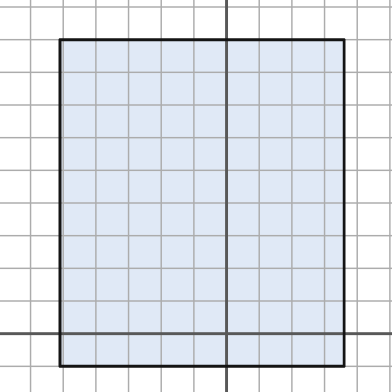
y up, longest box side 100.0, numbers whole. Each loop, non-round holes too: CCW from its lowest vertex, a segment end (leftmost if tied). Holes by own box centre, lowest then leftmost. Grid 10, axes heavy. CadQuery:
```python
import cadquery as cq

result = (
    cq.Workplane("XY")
    .moveTo(-51.0, -10.0)
    .lineTo(36.0, -10.0)
    .lineTo(36.0, 90.0)
    .lineTo(-51.0, 90.0)
    .close()
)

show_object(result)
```